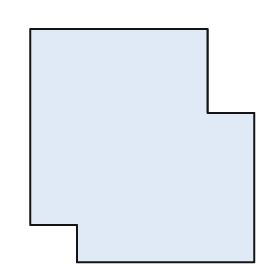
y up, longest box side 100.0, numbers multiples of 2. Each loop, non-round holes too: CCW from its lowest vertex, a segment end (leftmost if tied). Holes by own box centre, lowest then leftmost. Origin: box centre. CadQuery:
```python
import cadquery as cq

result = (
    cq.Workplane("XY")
    .moveTo(-28.0, -50.0)
    .lineTo(48.0, -50.0)
    .lineTo(48.0, 14.0)
    .lineTo(28.0, 14.0)
    .lineTo(28.0, 50.0)
    .lineTo(-48.0, 50.0)
    .lineTo(-48.0, -34.0)
    .lineTo(-28.0, -34.0)
    .close()
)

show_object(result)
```